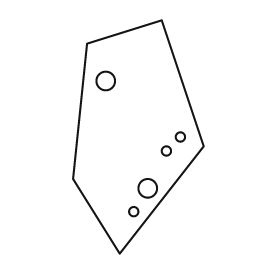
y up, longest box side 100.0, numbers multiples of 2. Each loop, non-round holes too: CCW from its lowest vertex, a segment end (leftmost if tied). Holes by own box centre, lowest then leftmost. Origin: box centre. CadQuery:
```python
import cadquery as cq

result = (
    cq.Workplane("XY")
    .moveTo(-8.0, -50.0)
    .lineTo(28.0, -4.0)
    .lineTo(10.0, 50.0)
    .lineTo(-22.0, 40.0)
    .lineTo(-28.0, -18.0)
    .close()
    .moveTo(-2.0, -32.0)
    .circle(2.0)
    .moveTo(4.0, -22.0)
    .circle(4.0)
    .moveTo(12.0, -6.0)
    .circle(2.0)
    .moveTo(18.0, 0.0)
    .circle(2.0)
    .moveTo(-14.0, 24.0)
    .circle(4.0)
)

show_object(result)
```